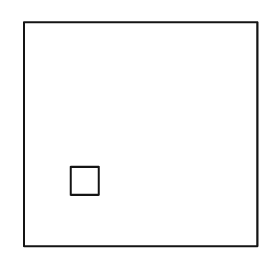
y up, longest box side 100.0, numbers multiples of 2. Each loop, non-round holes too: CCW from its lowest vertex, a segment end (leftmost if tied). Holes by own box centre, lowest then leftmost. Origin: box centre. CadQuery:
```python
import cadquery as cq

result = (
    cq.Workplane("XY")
    .moveTo(-50.0, -48.0)
    .lineTo(50.0, -48.0)
    .lineTo(50.0, 48.0)
    .lineTo(-50.0, 48.0)
    .close()
    .moveTo(-30.0, -26.0)
    .lineTo(-18.0, -26.0)
    .lineTo(-18.0, -14.0)
    .lineTo(-30.0, -14.0)
    .close()
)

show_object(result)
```